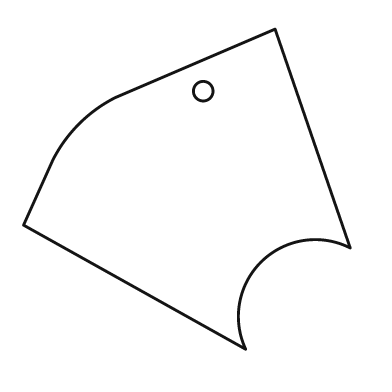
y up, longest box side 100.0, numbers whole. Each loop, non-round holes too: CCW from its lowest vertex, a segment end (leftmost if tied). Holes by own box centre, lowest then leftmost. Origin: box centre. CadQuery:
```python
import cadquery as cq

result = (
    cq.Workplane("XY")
    .moveTo(18.0, -49.0)
    .threePointArc((23.0, -22.0), (50.0, -18.0))
    .lineTo(27.0, 49.0)
    .lineTo(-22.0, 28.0)
    .threePointArc((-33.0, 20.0), (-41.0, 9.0))
    .lineTo(-50.0, -11.0)
    .close()
    .moveTo(5.0, 30.0)
    .circle(3.0)
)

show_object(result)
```